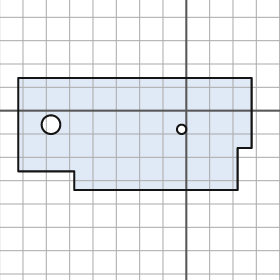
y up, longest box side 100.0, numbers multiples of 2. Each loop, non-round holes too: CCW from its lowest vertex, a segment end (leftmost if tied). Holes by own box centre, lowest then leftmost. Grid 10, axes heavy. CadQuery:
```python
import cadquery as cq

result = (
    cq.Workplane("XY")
    .moveTo(-48.0, -34.0)
    .lineTo(22.0, -34.0)
    .lineTo(22.0, -16.0)
    .lineTo(28.0, -16.0)
    .lineTo(28.0, 14.0)
    .lineTo(-72.0, 14.0)
    .lineTo(-72.0, -26.0)
    .lineTo(-48.0, -26.0)
    .close()
    .moveTo(-2.0, -8.0)
    .circle(2.0)
    .moveTo(-58.0, -6.0)
    .circle(4.0)
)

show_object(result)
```